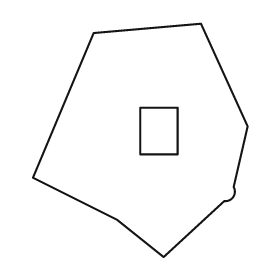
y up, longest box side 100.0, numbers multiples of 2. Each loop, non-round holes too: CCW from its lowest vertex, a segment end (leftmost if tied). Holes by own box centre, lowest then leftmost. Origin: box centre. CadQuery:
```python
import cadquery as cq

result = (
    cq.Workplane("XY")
    .moveTo(10.0, -50.0)
    .lineTo(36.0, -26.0)
    .threePointArc((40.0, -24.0), (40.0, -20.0))
    .lineTo(46.0, 6.0)
    .lineTo(26.0, 50.0)
    .lineTo(-20.0, 46.0)
    .lineTo(-46.0, -16.0)
    .lineTo(-10.0, -34.0)
    .close()
    .moveTo(0.0, -6.0)
    .lineTo(16.0, -6.0)
    .lineTo(16.0, 14.0)
    .lineTo(0.0, 14.0)
    .close()
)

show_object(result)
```